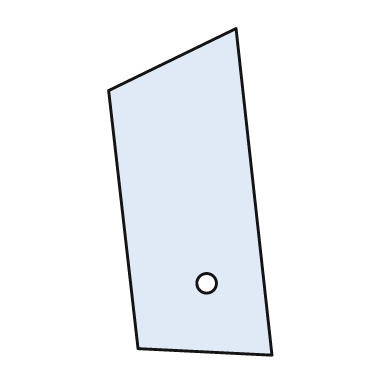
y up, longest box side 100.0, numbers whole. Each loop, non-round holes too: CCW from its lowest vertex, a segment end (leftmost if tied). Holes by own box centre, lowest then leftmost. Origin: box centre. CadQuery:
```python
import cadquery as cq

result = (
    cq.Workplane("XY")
    .moveTo(25.0, -50.0)
    .lineTo(14.0, 50.0)
    .lineTo(-25.0, 31.0)
    .lineTo(-16.0, -48.0)
    .close()
    .moveTo(5.0, -28.0)
    .circle(3.0)
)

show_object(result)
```